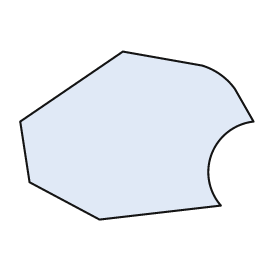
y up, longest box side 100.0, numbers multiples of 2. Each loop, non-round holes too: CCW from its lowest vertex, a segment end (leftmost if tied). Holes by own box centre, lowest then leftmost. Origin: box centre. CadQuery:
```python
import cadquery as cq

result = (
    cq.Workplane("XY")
    .moveTo(-16.0, -36.0)
    .lineTo(36.0, -30.0)
    .threePointArc((32.0, -8.0), (50.0, 6.0))
    .lineTo(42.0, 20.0)
    .threePointArc((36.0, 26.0), (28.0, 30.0))
    .lineTo(-6.0, 36.0)
    .lineTo(-50.0, 6.0)
    .lineTo(-46.0, -20.0)
    .close()
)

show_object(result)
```